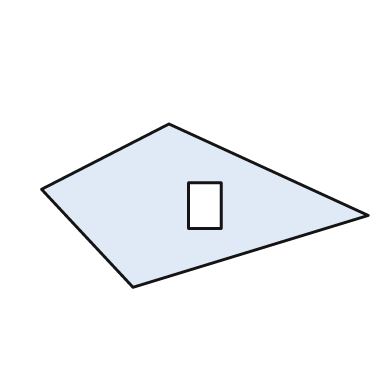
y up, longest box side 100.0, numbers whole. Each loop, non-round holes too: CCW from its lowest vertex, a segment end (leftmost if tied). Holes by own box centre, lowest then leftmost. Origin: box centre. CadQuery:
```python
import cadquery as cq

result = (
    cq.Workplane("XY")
    .moveTo(-22.0, -25.0)
    .lineTo(50.0, -3.0)
    .lineTo(-11.0, 25.0)
    .lineTo(-50.0, 5.0)
    .close()
    .moveTo(-5.0, -7.0)
    .lineTo(5.0, -7.0)
    .lineTo(5.0, 7.0)
    .lineTo(-5.0, 7.0)
    .close()
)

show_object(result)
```